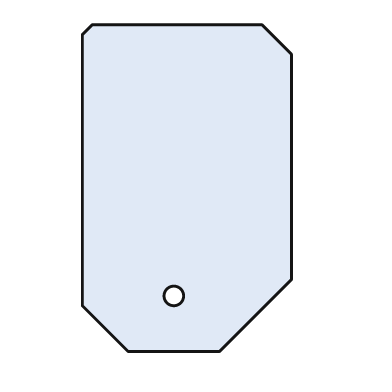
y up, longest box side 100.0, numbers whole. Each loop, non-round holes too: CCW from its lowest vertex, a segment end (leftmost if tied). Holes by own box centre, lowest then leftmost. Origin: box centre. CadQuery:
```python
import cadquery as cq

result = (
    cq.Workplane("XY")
    .moveTo(-18.0, -50.0)
    .lineTo(10.0, -50.0)
    .lineTo(32.0, -28.0)
    .lineTo(32.0, 41.0)
    .lineTo(23.0, 50.0)
    .lineTo(-29.0, 50.0)
    .lineTo(-32.0, 47.0)
    .lineTo(-32.0, -36.0)
    .close()
    .moveTo(-4.0, -33.0)
    .circle(3.0)
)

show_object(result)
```